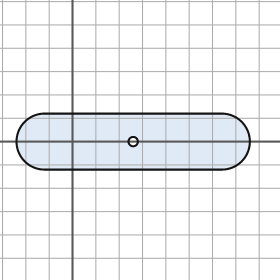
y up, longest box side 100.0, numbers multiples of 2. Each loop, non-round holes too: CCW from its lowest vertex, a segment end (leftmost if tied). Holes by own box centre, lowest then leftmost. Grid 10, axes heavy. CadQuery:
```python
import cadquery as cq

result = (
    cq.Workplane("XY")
    .moveTo(-12.0, -12.0)
    .lineTo(64.0, -12.0)
    .threePointArc((76.0, 0.0), (64.0, 12.0))
    .lineTo(-12.0, 12.0)
    .threePointArc((-24.0, 0.0), (-12.0, -12.0))
    .close()
    .moveTo(26.0, 0.0)
    .circle(2.0)
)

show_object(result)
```